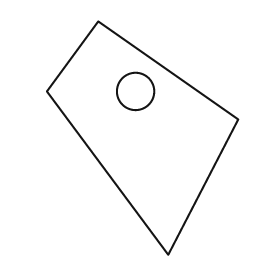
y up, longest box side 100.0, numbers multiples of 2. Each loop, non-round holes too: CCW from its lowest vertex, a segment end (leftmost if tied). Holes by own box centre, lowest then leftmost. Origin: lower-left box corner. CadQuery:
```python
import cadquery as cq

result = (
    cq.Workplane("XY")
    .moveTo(52.0, 0.0)
    .lineTo(82.0, 58.0)
    .lineTo(22.0, 100.0)
    .lineTo(0.0, 70.0)
    .close()
    .moveTo(38.0, 70.0)
    .circle(8.0)
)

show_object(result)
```